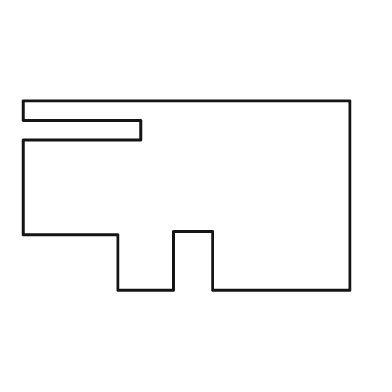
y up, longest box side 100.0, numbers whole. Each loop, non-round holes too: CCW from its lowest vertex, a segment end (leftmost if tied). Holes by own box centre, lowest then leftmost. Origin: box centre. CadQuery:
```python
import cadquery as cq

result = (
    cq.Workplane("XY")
    .moveTo(-21.0, -29.0)
    .lineTo(-4.0, -29.0)
    .lineTo(-4.0, -11.0)
    .lineTo(8.0, -11.0)
    .lineTo(8.0, -29.0)
    .lineTo(50.0, -29.0)
    .lineTo(50.0, 29.0)
    .lineTo(-50.0, 29.0)
    .lineTo(-50.0, 23.0)
    .lineTo(-14.0, 23.0)
    .lineTo(-14.0, 17.0)
    .lineTo(-50.0, 17.0)
    .lineTo(-50.0, -12.0)
    .lineTo(-21.0, -12.0)
    .close()
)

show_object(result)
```